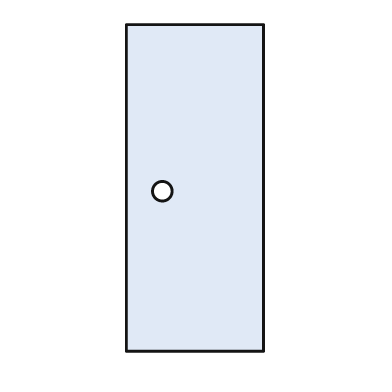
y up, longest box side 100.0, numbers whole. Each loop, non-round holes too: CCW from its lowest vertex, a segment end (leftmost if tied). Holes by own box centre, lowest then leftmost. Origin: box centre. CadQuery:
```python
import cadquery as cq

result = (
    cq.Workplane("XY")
    .moveTo(-21.0, -50.0)
    .lineTo(21.0, -50.0)
    .lineTo(21.0, 50.0)
    .lineTo(-21.0, 50.0)
    .close()
    .moveTo(-10.0, -1.0)
    .circle(3.0)
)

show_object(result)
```